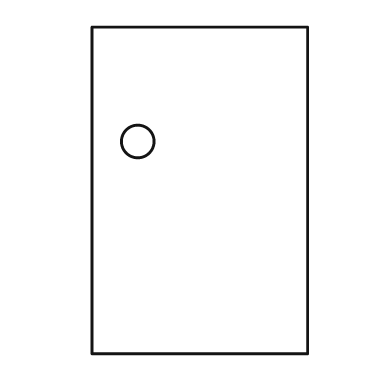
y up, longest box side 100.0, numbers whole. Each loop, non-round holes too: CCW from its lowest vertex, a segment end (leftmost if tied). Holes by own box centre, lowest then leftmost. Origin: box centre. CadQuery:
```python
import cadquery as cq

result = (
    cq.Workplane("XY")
    .moveTo(-33.0, -50.0)
    .lineTo(33.0, -50.0)
    .lineTo(33.0, 50.0)
    .lineTo(-33.0, 50.0)
    .close()
    .moveTo(-19.0, 15.0)
    .circle(5.0)
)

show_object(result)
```